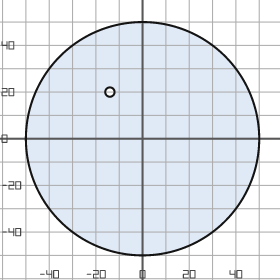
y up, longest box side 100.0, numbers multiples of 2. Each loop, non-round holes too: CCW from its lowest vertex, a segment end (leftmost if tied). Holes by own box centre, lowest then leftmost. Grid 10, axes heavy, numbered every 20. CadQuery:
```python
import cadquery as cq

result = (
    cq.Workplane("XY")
    .moveTo(0.0, 0.0)
    .circle(50.0)
    .moveTo(-14.0, 20.0)
    .circle(2.0)
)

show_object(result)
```